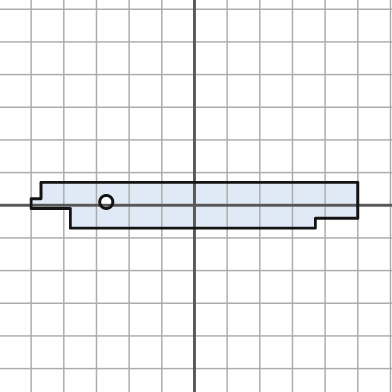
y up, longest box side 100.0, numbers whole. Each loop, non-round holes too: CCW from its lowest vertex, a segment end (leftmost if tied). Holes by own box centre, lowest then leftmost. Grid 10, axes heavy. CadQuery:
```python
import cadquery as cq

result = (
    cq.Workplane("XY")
    .moveTo(-38.0, -7.0)
    .lineTo(37.0, -7.0)
    .lineTo(37.0, -4.0)
    .lineTo(50.0, -4.0)
    .lineTo(50.0, 7.0)
    .lineTo(-47.0, 7.0)
    .lineTo(-47.0, 2.0)
    .lineTo(-50.0, 2.0)
    .lineTo(-50.0, -1.0)
    .lineTo(-38.0, -1.0)
    .close()
    .moveTo(-27.0, 1.0)
    .circle(2.0)
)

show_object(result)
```